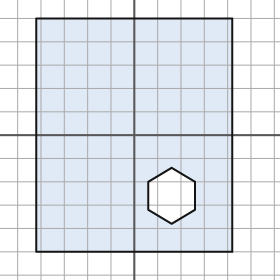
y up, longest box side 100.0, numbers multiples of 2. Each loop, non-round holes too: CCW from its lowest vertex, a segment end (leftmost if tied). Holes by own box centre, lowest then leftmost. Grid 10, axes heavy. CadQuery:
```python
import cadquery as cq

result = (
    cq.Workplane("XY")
    .moveTo(-42.0, -50.0)
    .lineTo(42.0, -50.0)
    .lineTo(42.0, 50.0)
    .lineTo(-42.0, 50.0)
    .close()
    .moveTo(16.0, -38.0)
    .lineTo(26.0, -32.0)
    .lineTo(26.0, -20.0)
    .lineTo(16.0, -14.0)
    .lineTo(6.0, -20.0)
    .lineTo(6.0, -32.0)
    .close()
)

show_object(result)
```